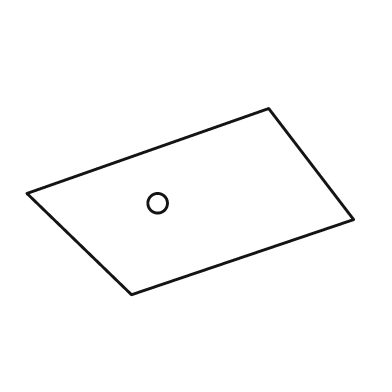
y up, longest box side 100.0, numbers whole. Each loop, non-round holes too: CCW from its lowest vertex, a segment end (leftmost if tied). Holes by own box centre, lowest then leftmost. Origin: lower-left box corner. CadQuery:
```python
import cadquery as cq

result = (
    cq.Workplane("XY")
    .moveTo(32.0, 0.0)
    .lineTo(100.0, 23.0)
    .lineTo(74.0, 57.0)
    .lineTo(0.0, 31.0)
    .close()
    .moveTo(40.0, 28.0)
    .circle(3.0)
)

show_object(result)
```